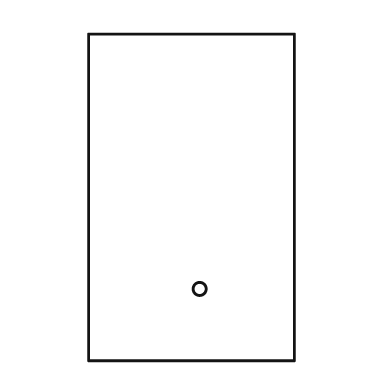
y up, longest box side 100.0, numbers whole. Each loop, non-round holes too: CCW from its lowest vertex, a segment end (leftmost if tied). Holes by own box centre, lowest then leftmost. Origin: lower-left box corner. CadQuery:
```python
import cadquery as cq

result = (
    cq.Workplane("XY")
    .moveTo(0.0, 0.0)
    .lineTo(63.0, 0.0)
    .lineTo(63.0, 100.0)
    .lineTo(0.0, 100.0)
    .close()
    .moveTo(34.0, 22.0)
    .circle(2.0)
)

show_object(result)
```